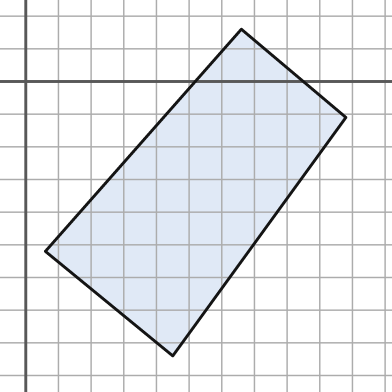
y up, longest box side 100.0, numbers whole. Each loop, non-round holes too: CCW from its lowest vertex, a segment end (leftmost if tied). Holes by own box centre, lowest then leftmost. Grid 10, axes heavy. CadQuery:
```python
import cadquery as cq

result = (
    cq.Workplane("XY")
    .moveTo(45.0, -84.0)
    .lineTo(98.0, -11.0)
    .lineTo(66.0, 16.0)
    .lineTo(6.0, -52.0)
    .close()
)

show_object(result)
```